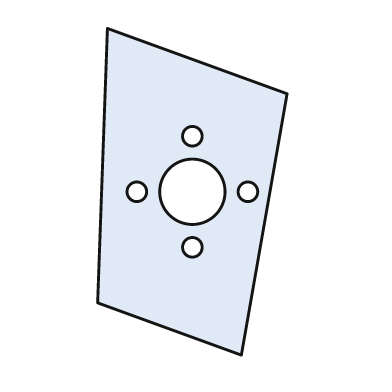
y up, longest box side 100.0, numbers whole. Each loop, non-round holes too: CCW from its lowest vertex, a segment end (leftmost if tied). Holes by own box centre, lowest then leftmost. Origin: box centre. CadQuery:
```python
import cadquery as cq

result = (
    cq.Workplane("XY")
    .moveTo(15.0, -50.0)
    .lineTo(29.0, 30.0)
    .lineTo(-26.0, 50.0)
    .lineTo(-29.0, -34.0)
    .close()
    .moveTo(0.0, -17.0)
    .circle(3.0)
    .moveTo(-17.0, 0.0)
    .circle(3.0)
    .moveTo(0.0, 0.0)
    .circle(10.0)
    .moveTo(17.0, 0.0)
    .circle(3.0)
    .moveTo(0.0, 17.0)
    .circle(3.0)
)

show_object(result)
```